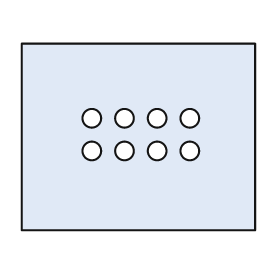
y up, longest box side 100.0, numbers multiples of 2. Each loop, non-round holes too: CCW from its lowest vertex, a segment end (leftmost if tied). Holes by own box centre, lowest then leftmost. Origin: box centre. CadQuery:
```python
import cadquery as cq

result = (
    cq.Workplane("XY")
    .moveTo(-50.0, -40.0)
    .lineTo(50.0, -40.0)
    .lineTo(50.0, 40.0)
    .lineTo(-50.0, 40.0)
    .close()
    .moveTo(-20.0, -6.0)
    .circle(4.0)
    .moveTo(-6.0, -6.0)
    .circle(4.0)
    .moveTo(8.0, -6.0)
    .circle(4.0)
    .moveTo(22.0, -6.0)
    .circle(4.0)
    .moveTo(-20.0, 8.0)
    .circle(4.0)
    .moveTo(-6.0, 8.0)
    .circle(4.0)
    .moveTo(8.0, 8.0)
    .circle(4.0)
    .moveTo(22.0, 8.0)
    .circle(4.0)
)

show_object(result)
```